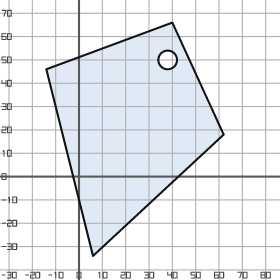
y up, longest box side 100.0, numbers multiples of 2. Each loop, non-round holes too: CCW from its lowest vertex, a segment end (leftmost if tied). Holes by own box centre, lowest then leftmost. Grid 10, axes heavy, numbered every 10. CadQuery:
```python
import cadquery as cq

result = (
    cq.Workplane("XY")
    .moveTo(6.0, -34.0)
    .lineTo(62.0, 18.0)
    .lineTo(40.0, 66.0)
    .lineTo(-14.0, 46.0)
    .close()
    .moveTo(38.0, 50.0)
    .circle(4.0)
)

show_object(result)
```